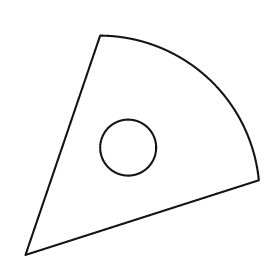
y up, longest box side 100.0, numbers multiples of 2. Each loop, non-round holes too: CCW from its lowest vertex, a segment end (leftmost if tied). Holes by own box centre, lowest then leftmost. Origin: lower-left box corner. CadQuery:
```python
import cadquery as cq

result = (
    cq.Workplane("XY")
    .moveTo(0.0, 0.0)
    .lineTo(100.0, 32.0)
    .threePointArc((78.0, 76.0), (32.0, 94.0))
    .close()
    .moveTo(44.0, 46.0)
    .circle(12.0)
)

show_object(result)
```